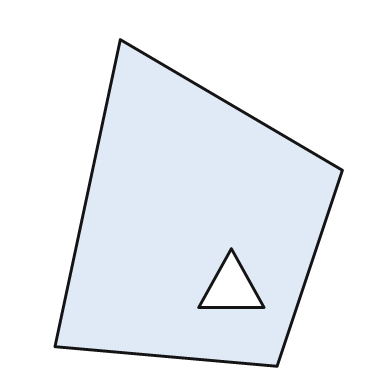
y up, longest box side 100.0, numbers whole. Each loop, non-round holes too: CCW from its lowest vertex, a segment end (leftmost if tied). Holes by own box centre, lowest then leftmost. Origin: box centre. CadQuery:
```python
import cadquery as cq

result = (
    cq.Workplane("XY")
    .moveTo(24.0, -50.0)
    .lineTo(44.0, 10.0)
    .lineTo(-24.0, 50.0)
    .lineTo(-44.0, -44.0)
    .close()
    .moveTo(0.0, -32.0)
    .lineTo(20.0, -32.0)
    .lineTo(10.0, -14.0)
    .close()
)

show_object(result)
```